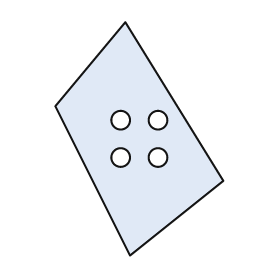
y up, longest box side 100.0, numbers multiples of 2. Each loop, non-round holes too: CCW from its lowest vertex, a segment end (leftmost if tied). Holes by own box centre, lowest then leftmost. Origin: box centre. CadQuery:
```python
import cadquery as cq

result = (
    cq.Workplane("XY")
    .moveTo(-4.0, -50.0)
    .lineTo(36.0, -18.0)
    .lineTo(-6.0, 50.0)
    .lineTo(-36.0, 14.0)
    .close()
    .moveTo(-8.0, -8.0)
    .circle(4.0)
    .moveTo(8.0, -8.0)
    .circle(4.0)
    .moveTo(-8.0, 8.0)
    .circle(4.0)
    .moveTo(8.0, 8.0)
    .circle(4.0)
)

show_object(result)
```